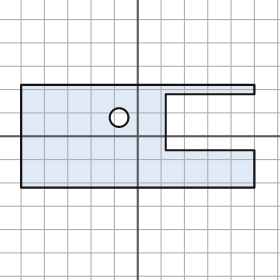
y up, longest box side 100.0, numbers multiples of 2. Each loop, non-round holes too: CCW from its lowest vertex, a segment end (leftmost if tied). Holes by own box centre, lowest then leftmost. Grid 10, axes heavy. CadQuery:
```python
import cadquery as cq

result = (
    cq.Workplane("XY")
    .moveTo(-50.0, -22.0)
    .lineTo(50.0, -22.0)
    .lineTo(50.0, -6.0)
    .lineTo(12.0, -6.0)
    .lineTo(12.0, 18.0)
    .lineTo(50.0, 18.0)
    .lineTo(50.0, 22.0)
    .lineTo(-50.0, 22.0)
    .close()
    .moveTo(-8.0, 8.0)
    .circle(4.0)
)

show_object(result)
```